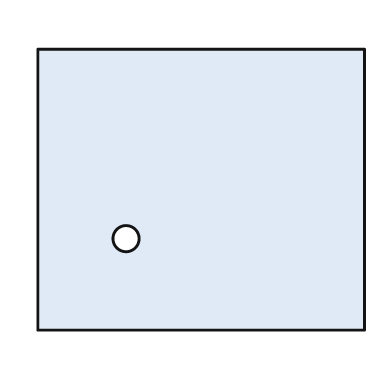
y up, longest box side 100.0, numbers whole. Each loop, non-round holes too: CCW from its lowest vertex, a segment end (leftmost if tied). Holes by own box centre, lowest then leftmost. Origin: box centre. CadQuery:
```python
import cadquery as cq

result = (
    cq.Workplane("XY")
    .moveTo(-50.0, -43.0)
    .lineTo(50.0, -43.0)
    .lineTo(50.0, 43.0)
    .lineTo(-50.0, 43.0)
    .close()
    .moveTo(-23.0, -15.0)
    .circle(4.0)
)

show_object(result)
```